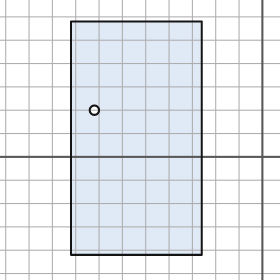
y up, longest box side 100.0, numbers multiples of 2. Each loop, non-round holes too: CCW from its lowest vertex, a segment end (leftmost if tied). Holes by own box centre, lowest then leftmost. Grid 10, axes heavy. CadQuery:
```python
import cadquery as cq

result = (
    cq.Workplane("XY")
    .moveTo(-82.0, -42.0)
    .lineTo(-26.0, -42.0)
    .lineTo(-26.0, 58.0)
    .lineTo(-82.0, 58.0)
    .close()
    .moveTo(-72.0, 20.0)
    .circle(2.0)
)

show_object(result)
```